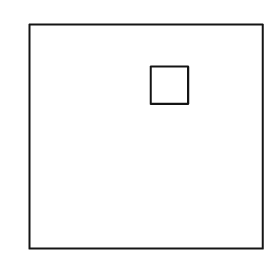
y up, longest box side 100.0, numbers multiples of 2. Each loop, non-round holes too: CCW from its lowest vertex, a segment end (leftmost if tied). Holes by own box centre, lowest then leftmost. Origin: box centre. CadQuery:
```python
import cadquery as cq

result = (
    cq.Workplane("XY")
    .moveTo(-50.0, -48.0)
    .lineTo(50.0, -48.0)
    .lineTo(50.0, 48.0)
    .lineTo(-50.0, 48.0)
    .close()
    .moveTo(2.0, 14.0)
    .lineTo(18.0, 14.0)
    .lineTo(18.0, 30.0)
    .lineTo(2.0, 30.0)
    .close()
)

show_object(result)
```